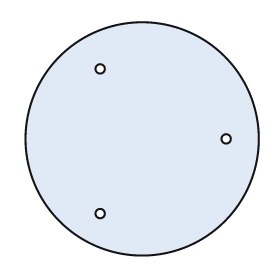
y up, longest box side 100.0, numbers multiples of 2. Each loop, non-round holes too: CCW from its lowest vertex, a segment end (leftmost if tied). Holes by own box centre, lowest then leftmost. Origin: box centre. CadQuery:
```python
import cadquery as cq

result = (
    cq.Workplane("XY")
    .moveTo(0.0, 0.0)
    .circle(50.0)
    .moveTo(-18.0, -32.0)
    .circle(2.0)
    .moveTo(36.0, 0.0)
    .circle(2.0)
    .moveTo(-18.0, 30.0)
    .circle(2.0)
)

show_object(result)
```